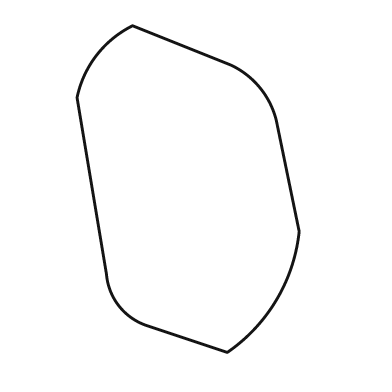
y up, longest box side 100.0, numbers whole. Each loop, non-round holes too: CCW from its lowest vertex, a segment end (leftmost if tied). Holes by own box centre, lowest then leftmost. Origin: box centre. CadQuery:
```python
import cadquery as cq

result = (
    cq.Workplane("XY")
    .moveTo(12.0, -50.0)
    .threePointArc((27.0, -34.0), (34.0, -13.0))
    .lineTo(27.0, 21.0)
    .threePointArc((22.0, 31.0), (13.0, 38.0))
    .lineTo(-17.0, 50.0)
    .threePointArc((-28.0, 41.0), (-34.0, 28.0))
    .lineTo(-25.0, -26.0)
    .threePointArc((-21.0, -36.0), (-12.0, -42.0))
    .close()
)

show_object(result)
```